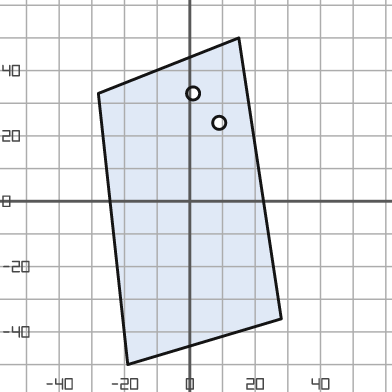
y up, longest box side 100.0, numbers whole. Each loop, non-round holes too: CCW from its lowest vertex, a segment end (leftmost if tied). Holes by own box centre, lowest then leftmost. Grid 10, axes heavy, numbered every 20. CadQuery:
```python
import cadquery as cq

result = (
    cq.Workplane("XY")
    .moveTo(-19.0, -50.0)
    .lineTo(28.0, -36.0)
    .lineTo(15.0, 50.0)
    .lineTo(-28.0, 33.0)
    .close()
    .moveTo(9.0, 24.0)
    .circle(2.0)
    .moveTo(1.0, 33.0)
    .circle(2.0)
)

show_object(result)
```